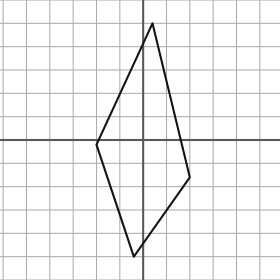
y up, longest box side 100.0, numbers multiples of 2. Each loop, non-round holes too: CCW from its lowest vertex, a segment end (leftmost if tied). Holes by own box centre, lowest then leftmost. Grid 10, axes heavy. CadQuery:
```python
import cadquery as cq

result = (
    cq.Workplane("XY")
    .moveTo(-4.0, -50.0)
    .lineTo(20.0, -16.0)
    .lineTo(4.0, 50.0)
    .lineTo(-20.0, -2.0)
    .close()
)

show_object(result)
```